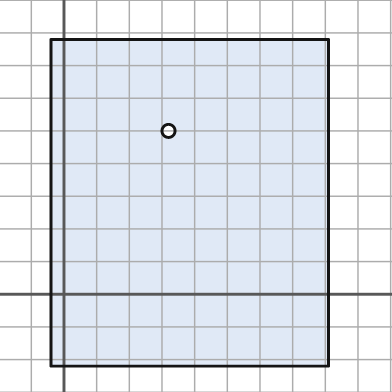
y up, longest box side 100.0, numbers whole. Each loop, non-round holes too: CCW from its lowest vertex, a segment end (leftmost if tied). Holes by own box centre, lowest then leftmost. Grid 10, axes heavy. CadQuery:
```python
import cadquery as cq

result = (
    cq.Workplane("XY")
    .moveTo(-4.0, -22.0)
    .lineTo(81.0, -22.0)
    .lineTo(81.0, 78.0)
    .lineTo(-4.0, 78.0)
    .close()
    .moveTo(32.0, 50.0)
    .circle(2.0)
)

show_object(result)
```